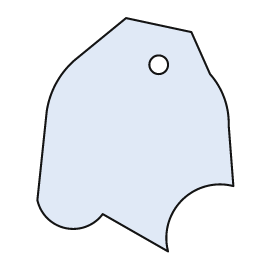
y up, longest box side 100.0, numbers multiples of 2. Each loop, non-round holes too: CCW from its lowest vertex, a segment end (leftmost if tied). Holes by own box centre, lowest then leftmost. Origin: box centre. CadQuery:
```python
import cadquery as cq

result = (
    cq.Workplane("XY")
    .moveTo(14.0, -50.0)
    .threePointArc((20.0, -28.0), (42.0, -22.0))
    .lineTo(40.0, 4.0)
    .threePointArc((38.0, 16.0), (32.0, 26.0))
    .lineTo(24.0, 44.0)
    .lineTo(-4.0, 50.0)
    .lineTo(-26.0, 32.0)
    .threePointArc((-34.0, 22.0), (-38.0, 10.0))
    .lineTo(-42.0, -28.0)
    .threePointArc((-30.0, -40.0), (-14.0, -34.0))
    .close()
    .moveTo(10.0, 30.0)
    .circle(4.0)
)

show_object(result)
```